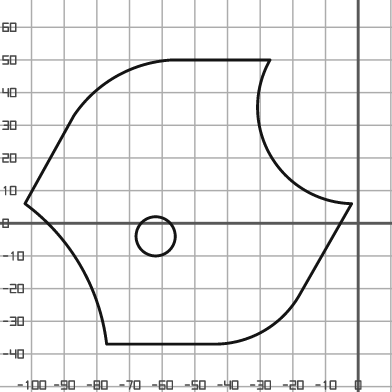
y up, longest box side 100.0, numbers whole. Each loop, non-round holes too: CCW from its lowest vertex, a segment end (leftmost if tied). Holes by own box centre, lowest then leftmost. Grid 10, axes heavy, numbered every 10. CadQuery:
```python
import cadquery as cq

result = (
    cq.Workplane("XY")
    .moveTo(-77.0, -37.0)
    .lineTo(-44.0, -37.0)
    .threePointArc((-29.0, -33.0), (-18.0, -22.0))
    .lineTo(-2.0, 6.0)
    .threePointArc((-27.0, 21.0), (-27.0, 50.0))
    .lineTo(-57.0, 50.0)
    .threePointArc((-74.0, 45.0), (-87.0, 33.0))
    .lineTo(-102.0, 6.0)
    .threePointArc((-85.0, -13.0), (-77.0, -37.0))
    .close()
    .moveTo(-62.0, -4.0)
    .circle(6.0)
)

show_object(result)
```